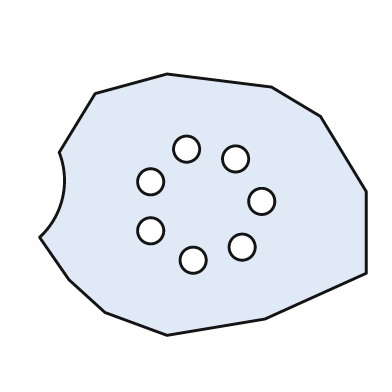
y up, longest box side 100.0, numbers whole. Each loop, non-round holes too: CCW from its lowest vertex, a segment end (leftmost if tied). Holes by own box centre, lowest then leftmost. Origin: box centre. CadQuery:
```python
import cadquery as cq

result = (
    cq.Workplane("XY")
    .moveTo(-11.0, -40.0)
    .lineTo(19.0, -35.0)
    .lineTo(50.0, -21.0)
    .lineTo(50.0, 4.0)
    .lineTo(36.0, 27.0)
    .lineTo(21.0, 36.0)
    .lineTo(-11.0, 40.0)
    .lineTo(-33.0, 34.0)
    .lineTo(-44.0, 16.0)
    .threePointArc((-43.0, 2.0), (-50.0, -10.0))
    .lineTo(-41.0, -23.0)
    .lineTo(-30.0, -33.0)
    .close()
    .moveTo(-3.0, -17.0)
    .circle(4.0)
    .moveTo(12.0, -13.0)
    .circle(4.0)
    .moveTo(-16.0, -8.0)
    .circle(4.0)
    .moveTo(18.0, 1.0)
    .circle(4.0)
    .moveTo(-16.0, 7.0)
    .circle(4.0)
    .moveTo(10.0, 14.0)
    .circle(4.0)
    .moveTo(-5.0, 17.0)
    .circle(4.0)
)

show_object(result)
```